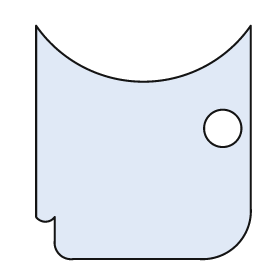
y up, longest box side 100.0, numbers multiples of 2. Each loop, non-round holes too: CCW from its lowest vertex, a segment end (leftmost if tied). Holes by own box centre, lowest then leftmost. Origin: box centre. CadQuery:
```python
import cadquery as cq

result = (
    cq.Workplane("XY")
    .moveTo(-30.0, -50.0)
    .lineTo(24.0, -50.0)
    .threePointArc((40.0, -44.0), (46.0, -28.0))
    .lineTo(46.0, 50.0)
    .threePointArc((0.0, 26.0), (-46.0, 50.0))
    .lineTo(-46.0, -32.0)
    .threePointArc((-42.0, -34.0), (-38.0, -32.0))
    .lineTo(-38.0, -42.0)
    .threePointArc((-36.0, -48.0), (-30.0, -50.0))
    .close()
    .moveTo(34.0, 6.0)
    .circle(8.0)
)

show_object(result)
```